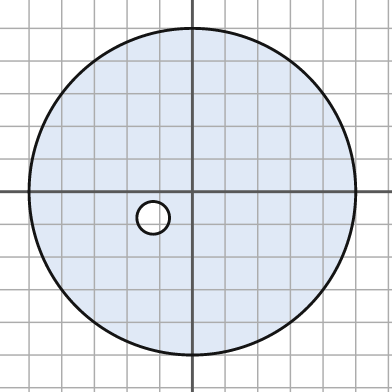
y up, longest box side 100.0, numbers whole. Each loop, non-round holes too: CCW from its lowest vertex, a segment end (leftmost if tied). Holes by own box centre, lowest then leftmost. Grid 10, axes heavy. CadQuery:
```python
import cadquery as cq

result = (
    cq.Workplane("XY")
    .moveTo(0.0, 0.0)
    .circle(50.0)
    .moveTo(-12.0, -8.0)
    .circle(5.0)
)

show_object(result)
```